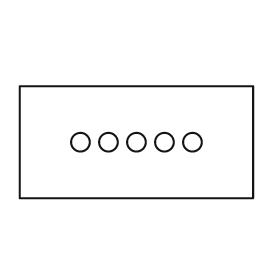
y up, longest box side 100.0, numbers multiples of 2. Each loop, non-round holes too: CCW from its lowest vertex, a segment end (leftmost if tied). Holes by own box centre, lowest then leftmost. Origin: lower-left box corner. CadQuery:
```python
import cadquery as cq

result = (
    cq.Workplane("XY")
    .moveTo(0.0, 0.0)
    .lineTo(100.0, 0.0)
    .lineTo(100.0, 48.0)
    .lineTo(0.0, 48.0)
    .close()
    .moveTo(26.0, 24.0)
    .circle(4.0)
    .moveTo(38.0, 24.0)
    .circle(4.0)
    .moveTo(50.0, 24.0)
    .circle(4.0)
    .moveTo(62.0, 24.0)
    .circle(4.0)
    .moveTo(74.0, 24.0)
    .circle(4.0)
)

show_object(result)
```